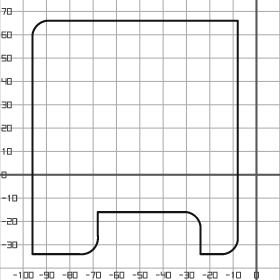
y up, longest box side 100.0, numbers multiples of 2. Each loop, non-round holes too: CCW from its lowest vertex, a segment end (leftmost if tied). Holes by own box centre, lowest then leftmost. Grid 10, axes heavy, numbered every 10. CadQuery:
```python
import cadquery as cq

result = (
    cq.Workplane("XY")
    .moveTo(-96.0, -34.0)
    .lineTo(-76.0, -34.0)
    .threePointArc((-70.0, -32.0), (-68.0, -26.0))
    .lineTo(-68.0, -16.0)
    .lineTo(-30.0, -16.0)
    .threePointArc((-26.0, -18.0), (-24.0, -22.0))
    .lineTo(-24.0, -34.0)
    .lineTo(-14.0, -34.0)
    .threePointArc((-10.0, -32.0), (-8.0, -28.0))
    .lineTo(-8.0, 66.0)
    .lineTo(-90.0, 66.0)
    .threePointArc((-94.0, 64.0), (-96.0, 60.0))
    .close()
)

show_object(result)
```